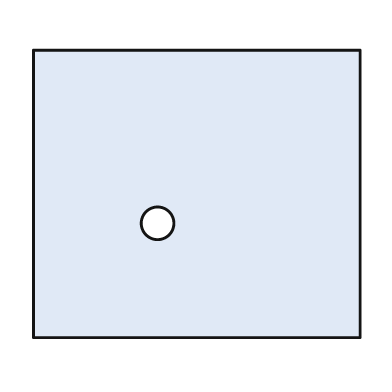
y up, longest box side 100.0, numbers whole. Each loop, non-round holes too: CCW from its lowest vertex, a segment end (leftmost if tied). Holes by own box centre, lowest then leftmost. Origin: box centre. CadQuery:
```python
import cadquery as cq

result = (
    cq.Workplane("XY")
    .moveTo(-50.0, -44.0)
    .lineTo(50.0, -44.0)
    .lineTo(50.0, 44.0)
    .lineTo(-50.0, 44.0)
    .close()
    .moveTo(-12.0, -9.0)
    .circle(5.0)
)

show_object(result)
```